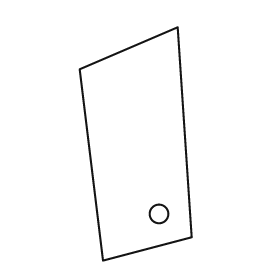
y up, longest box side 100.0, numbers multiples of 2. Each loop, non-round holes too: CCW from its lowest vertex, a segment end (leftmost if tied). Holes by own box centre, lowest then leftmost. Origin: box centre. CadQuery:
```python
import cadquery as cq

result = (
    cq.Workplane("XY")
    .moveTo(-14.0, -50.0)
    .lineTo(24.0, -40.0)
    .lineTo(18.0, 50.0)
    .lineTo(-24.0, 32.0)
    .close()
    .moveTo(10.0, -30.0)
    .circle(4.0)
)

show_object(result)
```